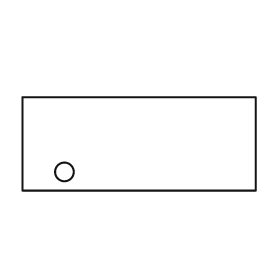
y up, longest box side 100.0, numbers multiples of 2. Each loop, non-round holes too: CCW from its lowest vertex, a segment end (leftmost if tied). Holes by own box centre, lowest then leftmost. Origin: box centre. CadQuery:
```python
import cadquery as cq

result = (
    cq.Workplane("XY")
    .moveTo(-50.0, -20.0)
    .lineTo(50.0, -20.0)
    .lineTo(50.0, 20.0)
    .lineTo(-50.0, 20.0)
    .close()
    .moveTo(-32.0, -12.0)
    .circle(4.0)
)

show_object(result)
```